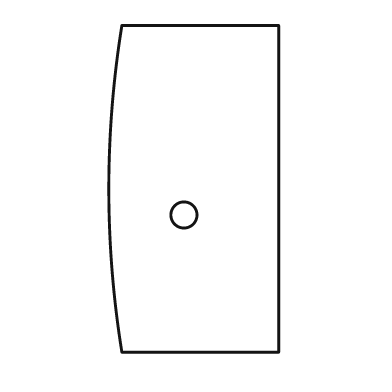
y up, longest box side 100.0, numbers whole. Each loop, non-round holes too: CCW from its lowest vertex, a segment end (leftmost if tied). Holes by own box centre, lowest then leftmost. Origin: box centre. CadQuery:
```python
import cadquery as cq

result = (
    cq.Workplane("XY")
    .moveTo(-22.0, -50.0)
    .lineTo(26.0, -50.0)
    .lineTo(26.0, 50.0)
    .lineTo(-22.0, 50.0)
    .threePointArc((-26.0, 0.0), (-22.0, -50.0))
    .close()
    .moveTo(-3.0, -8.0)
    .circle(4.0)
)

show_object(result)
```